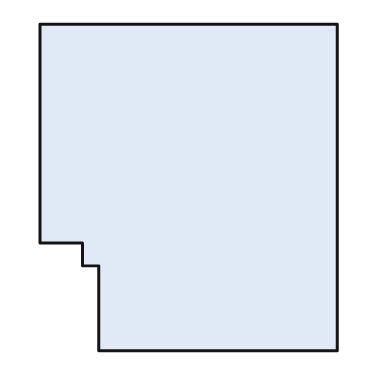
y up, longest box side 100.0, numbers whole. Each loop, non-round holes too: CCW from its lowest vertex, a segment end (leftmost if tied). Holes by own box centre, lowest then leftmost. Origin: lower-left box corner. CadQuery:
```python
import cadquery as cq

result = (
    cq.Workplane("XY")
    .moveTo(18.0, 0.0)
    .lineTo(91.0, 0.0)
    .lineTo(91.0, 100.0)
    .lineTo(0.0, 100.0)
    .lineTo(0.0, 33.0)
    .lineTo(13.0, 33.0)
    .lineTo(13.0, 26.0)
    .lineTo(18.0, 26.0)
    .close()
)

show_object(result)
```